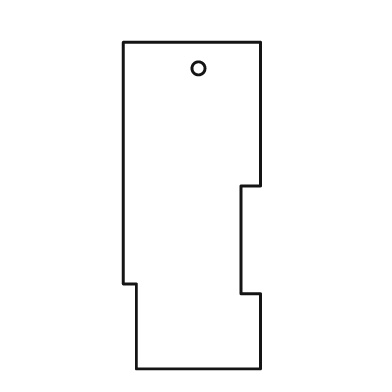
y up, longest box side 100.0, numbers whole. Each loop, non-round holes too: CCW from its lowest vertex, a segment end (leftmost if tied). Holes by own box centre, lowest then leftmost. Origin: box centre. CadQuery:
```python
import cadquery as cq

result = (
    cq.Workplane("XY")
    .moveTo(-17.0, -50.0)
    .lineTo(21.0, -50.0)
    .lineTo(21.0, -27.0)
    .lineTo(15.0, -27.0)
    .lineTo(15.0, 6.0)
    .lineTo(21.0, 6.0)
    .lineTo(21.0, 50.0)
    .lineTo(-21.0, 50.0)
    .lineTo(-21.0, -24.0)
    .lineTo(-17.0, -24.0)
    .close()
    .moveTo(2.0, 42.0)
    .circle(2.0)
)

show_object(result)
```